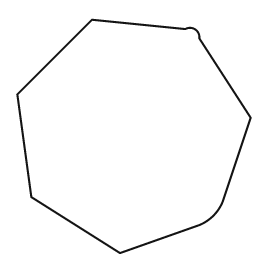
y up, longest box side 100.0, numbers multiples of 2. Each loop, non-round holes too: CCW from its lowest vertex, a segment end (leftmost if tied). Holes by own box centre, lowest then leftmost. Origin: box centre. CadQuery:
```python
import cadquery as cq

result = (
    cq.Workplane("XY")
    .moveTo(-6.0, -50.0)
    .lineTo(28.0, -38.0)
    .threePointArc((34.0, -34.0), (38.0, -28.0))
    .lineTo(50.0, 8.0)
    .lineTo(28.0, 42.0)
    .threePointArc((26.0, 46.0), (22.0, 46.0))
    .lineTo(-18.0, 50.0)
    .lineTo(-50.0, 18.0)
    .lineTo(-44.0, -26.0)
    .close()
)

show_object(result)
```